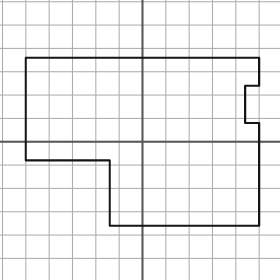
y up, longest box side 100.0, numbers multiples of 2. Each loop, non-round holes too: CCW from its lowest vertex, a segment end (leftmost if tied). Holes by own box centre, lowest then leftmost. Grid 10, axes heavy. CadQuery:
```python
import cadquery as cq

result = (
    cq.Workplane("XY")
    .moveTo(-14.0, -36.0)
    .lineTo(50.0, -36.0)
    .lineTo(50.0, 8.0)
    .lineTo(44.0, 8.0)
    .lineTo(44.0, 24.0)
    .lineTo(50.0, 24.0)
    .lineTo(50.0, 36.0)
    .lineTo(-50.0, 36.0)
    .lineTo(-50.0, -8.0)
    .lineTo(-14.0, -8.0)
    .close()
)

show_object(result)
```